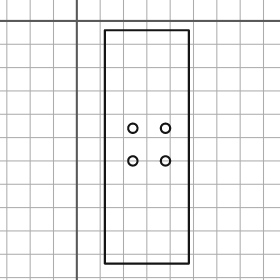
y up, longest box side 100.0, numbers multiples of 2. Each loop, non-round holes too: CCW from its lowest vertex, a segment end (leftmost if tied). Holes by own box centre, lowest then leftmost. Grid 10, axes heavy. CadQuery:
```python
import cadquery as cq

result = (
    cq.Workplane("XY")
    .moveTo(12.0, -104.0)
    .lineTo(48.0, -104.0)
    .lineTo(48.0, -4.0)
    .lineTo(12.0, -4.0)
    .close()
    .moveTo(24.0, -60.0)
    .circle(2.0)
    .moveTo(38.0, -60.0)
    .circle(2.0)
    .moveTo(24.0, -46.0)
    .circle(2.0)
    .moveTo(38.0, -46.0)
    .circle(2.0)
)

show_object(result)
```